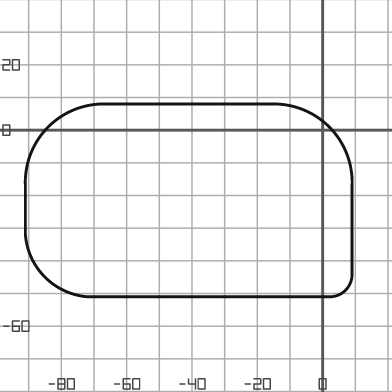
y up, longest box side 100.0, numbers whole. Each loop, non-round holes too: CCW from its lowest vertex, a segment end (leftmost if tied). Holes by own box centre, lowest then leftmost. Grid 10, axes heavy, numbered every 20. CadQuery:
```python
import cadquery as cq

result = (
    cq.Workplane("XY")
    .moveTo(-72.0, -51.0)
    .lineTo(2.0, -51.0)
    .threePointArc((7.0, -49.0), (9.0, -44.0))
    .lineTo(9.0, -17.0)
    .threePointArc((2.0, 1.0), (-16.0, 8.0))
    .lineTo(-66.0, 8.0)
    .threePointArc((-84.0, 1.0), (-91.0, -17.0))
    .lineTo(-91.0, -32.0)
    .threePointArc((-85.0, -45.0), (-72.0, -51.0))
    .close()
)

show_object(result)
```